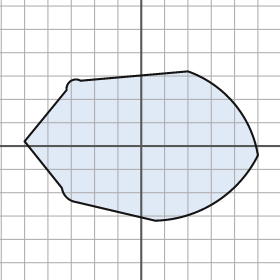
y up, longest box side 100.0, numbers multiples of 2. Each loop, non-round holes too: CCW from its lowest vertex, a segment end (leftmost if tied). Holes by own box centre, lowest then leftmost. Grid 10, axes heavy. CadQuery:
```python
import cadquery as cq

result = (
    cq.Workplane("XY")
    .moveTo(6.0, -32.0)
    .threePointArc((32.0, -24.0), (50.0, -4.0))
    .threePointArc((40.0, 18.0), (20.0, 32.0))
    .lineTo(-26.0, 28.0)
    .threePointArc((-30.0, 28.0), (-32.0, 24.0))
    .lineTo(-50.0, 2.0)
    .lineTo(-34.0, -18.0)
    .threePointArc((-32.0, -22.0), (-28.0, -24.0))
    .close()
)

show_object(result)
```